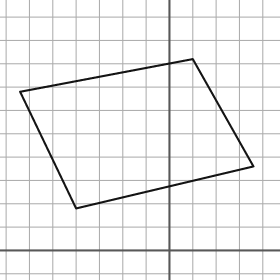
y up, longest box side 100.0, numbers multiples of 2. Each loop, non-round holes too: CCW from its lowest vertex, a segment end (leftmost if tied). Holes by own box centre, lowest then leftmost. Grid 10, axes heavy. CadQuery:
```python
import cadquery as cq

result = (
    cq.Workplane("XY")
    .moveTo(-40.0, 18.0)
    .lineTo(36.0, 36.0)
    .lineTo(10.0, 82.0)
    .lineTo(-64.0, 68.0)
    .close()
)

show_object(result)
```